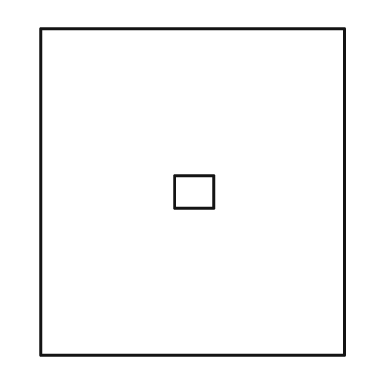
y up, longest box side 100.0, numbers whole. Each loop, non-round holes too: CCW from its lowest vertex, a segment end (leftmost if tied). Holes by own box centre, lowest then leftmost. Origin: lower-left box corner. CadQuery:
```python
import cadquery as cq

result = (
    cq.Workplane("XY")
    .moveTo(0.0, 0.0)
    .lineTo(93.0, 0.0)
    .lineTo(93.0, 100.0)
    .lineTo(0.0, 100.0)
    .close()
    .moveTo(41.0, 45.0)
    .lineTo(53.0, 45.0)
    .lineTo(53.0, 55.0)
    .lineTo(41.0, 55.0)
    .close()
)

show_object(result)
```